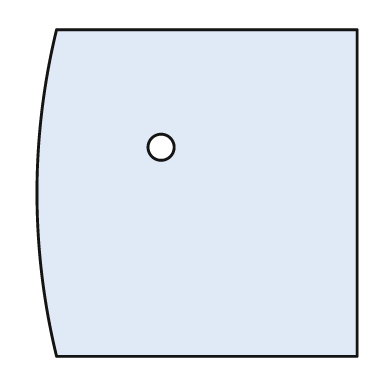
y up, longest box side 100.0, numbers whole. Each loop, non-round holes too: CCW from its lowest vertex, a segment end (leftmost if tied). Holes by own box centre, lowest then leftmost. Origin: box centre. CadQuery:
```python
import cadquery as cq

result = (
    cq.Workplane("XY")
    .moveTo(-43.0, -50.0)
    .lineTo(49.0, -50.0)
    .lineTo(49.0, 50.0)
    .lineTo(-43.0, 50.0)
    .threePointArc((-49.0, 0.0), (-43.0, -50.0))
    .close()
    .moveTo(-11.0, 14.0)
    .circle(4.0)
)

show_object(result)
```